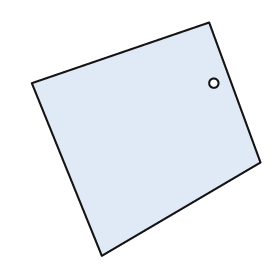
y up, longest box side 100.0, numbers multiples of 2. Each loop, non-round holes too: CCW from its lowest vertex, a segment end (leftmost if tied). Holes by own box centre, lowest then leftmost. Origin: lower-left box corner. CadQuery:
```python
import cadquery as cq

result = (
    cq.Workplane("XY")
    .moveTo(30.0, 0.0)
    .lineTo(98.0, 40.0)
    .lineTo(76.0, 100.0)
    .lineTo(0.0, 74.0)
    .close()
    .moveTo(78.0, 74.0)
    .circle(2.0)
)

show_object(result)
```